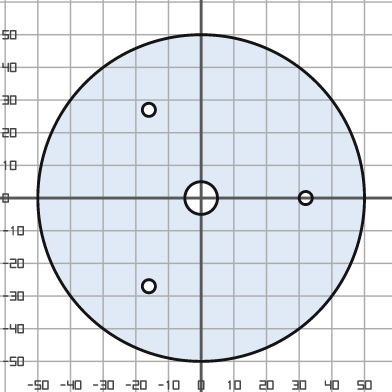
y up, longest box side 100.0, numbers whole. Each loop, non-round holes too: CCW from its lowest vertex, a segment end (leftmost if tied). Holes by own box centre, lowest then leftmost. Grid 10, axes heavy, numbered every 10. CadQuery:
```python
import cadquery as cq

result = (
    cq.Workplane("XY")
    .moveTo(0.0, 0.0)
    .circle(50.0)
    .moveTo(-16.0, -27.0)
    .circle(2.0)
    .moveTo(0.0, 0.0)
    .circle(5.0)
    .moveTo(32.0, 0.0)
    .circle(2.0)
    .moveTo(-16.0, 27.0)
    .circle(2.0)
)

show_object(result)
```